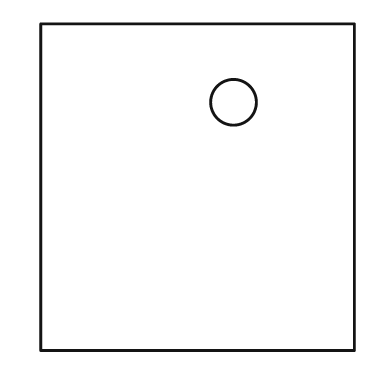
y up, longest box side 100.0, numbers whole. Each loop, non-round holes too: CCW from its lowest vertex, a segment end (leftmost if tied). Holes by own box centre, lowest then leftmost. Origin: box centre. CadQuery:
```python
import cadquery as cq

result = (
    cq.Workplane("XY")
    .moveTo(-48.0, -50.0)
    .lineTo(48.0, -50.0)
    .lineTo(48.0, 50.0)
    .lineTo(-48.0, 50.0)
    .close()
    .moveTo(11.0, 26.0)
    .circle(7.0)
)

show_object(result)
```